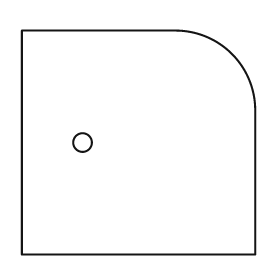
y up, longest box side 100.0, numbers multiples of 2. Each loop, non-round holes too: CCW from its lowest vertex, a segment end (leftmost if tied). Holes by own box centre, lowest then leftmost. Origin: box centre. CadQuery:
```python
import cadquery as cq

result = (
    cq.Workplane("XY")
    .moveTo(-50.0, -48.0)
    .lineTo(50.0, -48.0)
    .lineTo(50.0, 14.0)
    .threePointArc((40.0, 38.0), (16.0, 48.0))
    .lineTo(-50.0, 48.0)
    .close()
    .moveTo(-24.0, 0.0)
    .circle(4.0)
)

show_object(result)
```